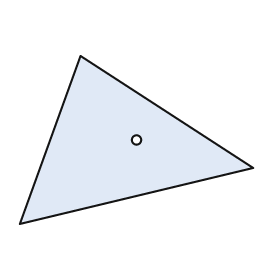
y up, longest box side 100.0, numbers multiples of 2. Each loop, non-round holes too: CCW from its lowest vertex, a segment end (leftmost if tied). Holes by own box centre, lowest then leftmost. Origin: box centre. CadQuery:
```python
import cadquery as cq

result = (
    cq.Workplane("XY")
    .moveTo(-50.0, -36.0)
    .lineTo(50.0, -12.0)
    .lineTo(-24.0, 36.0)
    .close()
    .moveTo(0.0, 0.0)
    .circle(2.0)
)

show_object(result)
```